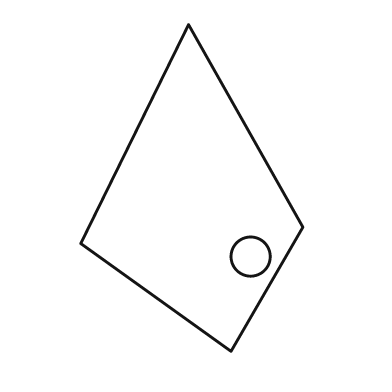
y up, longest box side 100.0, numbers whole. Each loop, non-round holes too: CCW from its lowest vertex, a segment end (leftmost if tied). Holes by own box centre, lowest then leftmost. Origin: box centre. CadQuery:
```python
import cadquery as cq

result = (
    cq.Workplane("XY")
    .moveTo(12.0, -50.0)
    .lineTo(34.0, -12.0)
    .lineTo(-1.0, 50.0)
    .lineTo(-34.0, -17.0)
    .close()
    .moveTo(18.0, -21.0)
    .circle(6.0)
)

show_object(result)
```